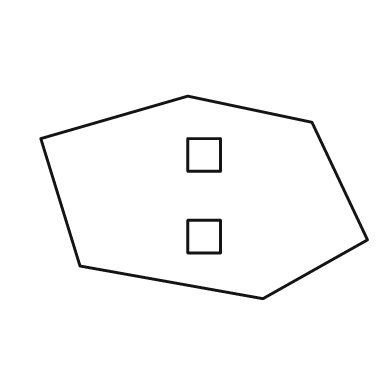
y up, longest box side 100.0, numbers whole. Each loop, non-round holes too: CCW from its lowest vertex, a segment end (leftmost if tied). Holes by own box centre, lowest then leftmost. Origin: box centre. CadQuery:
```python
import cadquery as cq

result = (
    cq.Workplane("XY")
    .moveTo(18.0, -31.0)
    .lineTo(50.0, -13.0)
    .lineTo(33.0, 23.0)
    .lineTo(-5.0, 31.0)
    .lineTo(-50.0, 18.0)
    .lineTo(-38.0, -21.0)
    .close()
    .moveTo(-5.0, -17.0)
    .lineTo(5.0, -17.0)
    .lineTo(5.0, -7.0)
    .lineTo(-5.0, -7.0)
    .close()
    .moveTo(-5.0, 8.0)
    .lineTo(5.0, 8.0)
    .lineTo(5.0, 18.0)
    .lineTo(-5.0, 18.0)
    .close()
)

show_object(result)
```